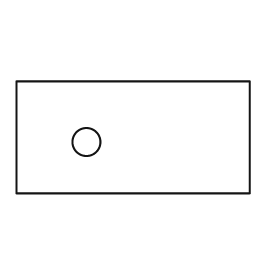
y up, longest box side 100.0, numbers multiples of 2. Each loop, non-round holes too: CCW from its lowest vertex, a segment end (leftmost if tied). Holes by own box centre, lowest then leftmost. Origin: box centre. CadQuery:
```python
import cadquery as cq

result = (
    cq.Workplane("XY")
    .moveTo(-50.0, -24.0)
    .lineTo(50.0, -24.0)
    .lineTo(50.0, 24.0)
    .lineTo(-50.0, 24.0)
    .close()
    .moveTo(-20.0, -2.0)
    .circle(6.0)
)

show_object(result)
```